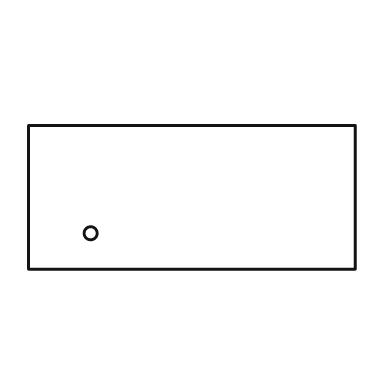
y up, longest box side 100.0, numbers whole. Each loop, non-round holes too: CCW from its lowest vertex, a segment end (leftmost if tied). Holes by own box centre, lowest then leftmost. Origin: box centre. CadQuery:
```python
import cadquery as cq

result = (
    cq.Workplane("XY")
    .moveTo(-50.0, -22.0)
    .lineTo(50.0, -22.0)
    .lineTo(50.0, 22.0)
    .lineTo(-50.0, 22.0)
    .close()
    .moveTo(-31.0, -11.0)
    .circle(2.0)
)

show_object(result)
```